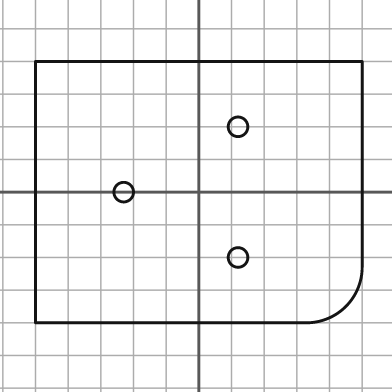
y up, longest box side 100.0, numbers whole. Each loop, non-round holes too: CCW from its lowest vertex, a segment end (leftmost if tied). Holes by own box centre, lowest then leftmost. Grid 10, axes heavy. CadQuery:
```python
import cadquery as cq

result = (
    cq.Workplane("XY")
    .moveTo(-50.0, -40.0)
    .lineTo(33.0, -40.0)
    .threePointArc((45.0, -35.0), (50.0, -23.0))
    .lineTo(50.0, 40.0)
    .lineTo(-50.0, 40.0)
    .close()
    .moveTo(12.0, -20.0)
    .circle(3.0)
    .moveTo(-23.0, 0.0)
    .circle(3.0)
    .moveTo(12.0, 20.0)
    .circle(3.0)
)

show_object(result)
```